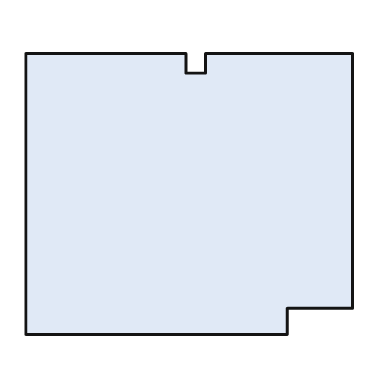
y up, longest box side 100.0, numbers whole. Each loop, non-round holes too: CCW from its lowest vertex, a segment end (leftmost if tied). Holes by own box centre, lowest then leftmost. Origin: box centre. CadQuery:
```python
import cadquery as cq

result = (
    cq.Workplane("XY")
    .moveTo(-50.0, -43.0)
    .lineTo(30.0, -43.0)
    .lineTo(30.0, -35.0)
    .lineTo(50.0, -35.0)
    .lineTo(50.0, 43.0)
    .lineTo(5.0, 43.0)
    .lineTo(5.0, 37.0)
    .lineTo(-1.0, 37.0)
    .lineTo(-1.0, 43.0)
    .lineTo(-50.0, 43.0)
    .close()
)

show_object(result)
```